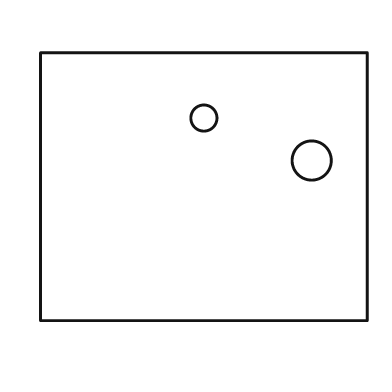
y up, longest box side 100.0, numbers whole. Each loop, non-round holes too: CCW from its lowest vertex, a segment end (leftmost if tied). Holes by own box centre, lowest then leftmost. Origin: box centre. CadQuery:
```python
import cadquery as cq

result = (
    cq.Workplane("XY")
    .moveTo(-50.0, -41.0)
    .lineTo(50.0, -41.0)
    .lineTo(50.0, 41.0)
    .lineTo(-50.0, 41.0)
    .close()
    .moveTo(33.0, 8.0)
    .circle(6.0)
    .moveTo(0.0, 21.0)
    .circle(4.0)
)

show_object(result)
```